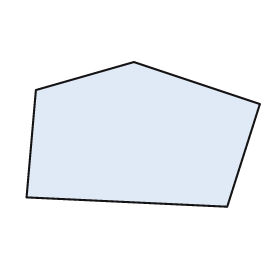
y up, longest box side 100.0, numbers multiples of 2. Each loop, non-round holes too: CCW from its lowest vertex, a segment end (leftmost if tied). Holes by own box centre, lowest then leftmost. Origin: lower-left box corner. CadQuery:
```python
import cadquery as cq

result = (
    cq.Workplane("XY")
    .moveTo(86.0, 0.0)
    .lineTo(100.0, 44.0)
    .lineTo(46.0, 62.0)
    .lineTo(4.0, 50.0)
    .lineTo(0.0, 4.0)
    .close()
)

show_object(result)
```